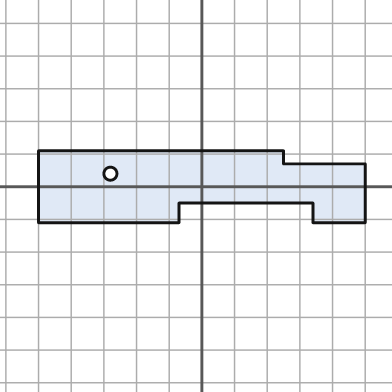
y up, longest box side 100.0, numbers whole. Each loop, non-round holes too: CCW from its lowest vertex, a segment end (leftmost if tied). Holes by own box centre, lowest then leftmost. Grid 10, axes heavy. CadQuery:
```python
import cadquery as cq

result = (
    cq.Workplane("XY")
    .moveTo(-50.0, -11.0)
    .lineTo(-7.0, -11.0)
    .lineTo(-7.0, -5.0)
    .lineTo(34.0, -5.0)
    .lineTo(34.0, -11.0)
    .lineTo(50.0, -11.0)
    .lineTo(50.0, 7.0)
    .lineTo(25.0, 7.0)
    .lineTo(25.0, 11.0)
    .lineTo(-50.0, 11.0)
    .close()
    .moveTo(-28.0, 4.0)
    .circle(2.0)
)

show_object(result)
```